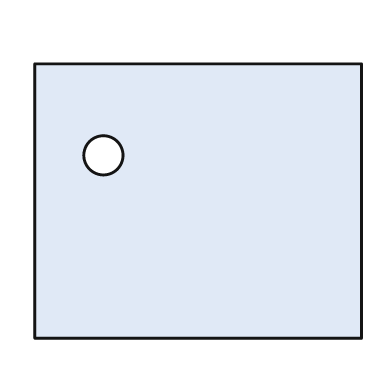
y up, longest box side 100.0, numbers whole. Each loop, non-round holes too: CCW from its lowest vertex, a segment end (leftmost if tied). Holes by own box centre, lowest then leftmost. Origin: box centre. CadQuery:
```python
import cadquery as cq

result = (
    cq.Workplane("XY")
    .moveTo(-50.0, -42.0)
    .lineTo(50.0, -42.0)
    .lineTo(50.0, 42.0)
    .lineTo(-50.0, 42.0)
    .close()
    .moveTo(-29.0, 14.0)
    .circle(6.0)
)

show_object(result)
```